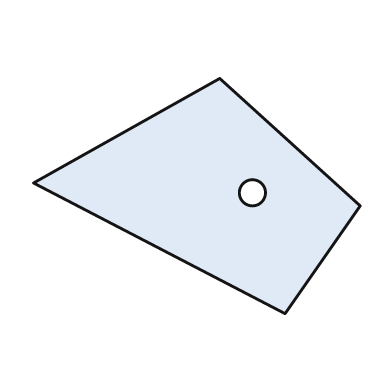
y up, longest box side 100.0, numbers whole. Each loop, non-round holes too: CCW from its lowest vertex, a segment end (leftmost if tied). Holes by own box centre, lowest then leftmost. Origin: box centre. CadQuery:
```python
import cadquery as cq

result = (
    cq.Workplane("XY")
    .moveTo(27.0, -36.0)
    .lineTo(50.0, -3.0)
    .lineTo(7.0, 36.0)
    .lineTo(-50.0, 4.0)
    .close()
    .moveTo(17.0, 1.0)
    .circle(4.0)
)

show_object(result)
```